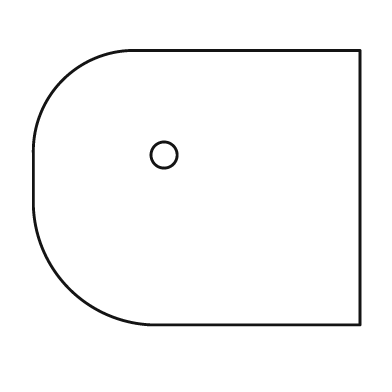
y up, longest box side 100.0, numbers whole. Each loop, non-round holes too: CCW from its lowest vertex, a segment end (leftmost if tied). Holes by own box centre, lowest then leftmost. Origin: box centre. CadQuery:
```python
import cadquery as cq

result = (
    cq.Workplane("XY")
    .moveTo(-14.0, -42.0)
    .lineTo(50.0, -42.0)
    .lineTo(50.0, 42.0)
    .lineTo(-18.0, 42.0)
    .threePointArc((-41.0, 33.0), (-50.0, 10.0))
    .lineTo(-50.0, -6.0)
    .threePointArc((-39.0, -31.0), (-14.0, -42.0))
    .close()
    .moveTo(-10.0, 10.0)
    .circle(4.0)
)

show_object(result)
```